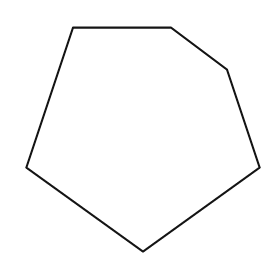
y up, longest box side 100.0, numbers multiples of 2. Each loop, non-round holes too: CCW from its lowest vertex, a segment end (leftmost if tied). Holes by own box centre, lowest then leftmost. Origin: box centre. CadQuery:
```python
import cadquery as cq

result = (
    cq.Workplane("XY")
    .moveTo(0.0, -48.0)
    .lineTo(50.0, -12.0)
    .lineTo(36.0, 30.0)
    .lineTo(12.0, 48.0)
    .lineTo(-30.0, 48.0)
    .lineTo(-50.0, -12.0)
    .close()
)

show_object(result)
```